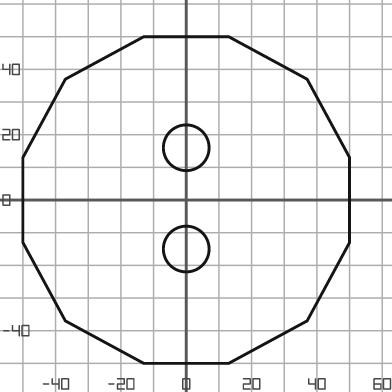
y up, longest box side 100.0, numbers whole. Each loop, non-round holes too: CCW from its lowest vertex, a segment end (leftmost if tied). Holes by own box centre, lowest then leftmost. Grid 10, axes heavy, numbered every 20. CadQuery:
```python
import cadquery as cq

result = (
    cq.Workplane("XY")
    .moveTo(-13.0, -50.0)
    .lineTo(13.0, -50.0)
    .lineTo(37.0, -37.0)
    .lineTo(50.0, -13.0)
    .lineTo(50.0, 13.0)
    .lineTo(37.0, 37.0)
    .lineTo(13.0, 50.0)
    .lineTo(-13.0, 50.0)
    .lineTo(-37.0, 37.0)
    .lineTo(-50.0, 13.0)
    .lineTo(-50.0, -13.0)
    .lineTo(-37.0, -37.0)
    .close()
    .moveTo(0.0, -15.0)
    .circle(7.0)
    .moveTo(0.0, 16.0)
    .circle(7.0)
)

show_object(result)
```